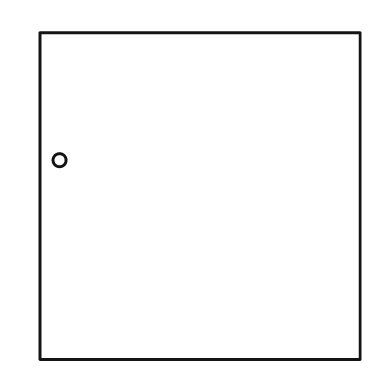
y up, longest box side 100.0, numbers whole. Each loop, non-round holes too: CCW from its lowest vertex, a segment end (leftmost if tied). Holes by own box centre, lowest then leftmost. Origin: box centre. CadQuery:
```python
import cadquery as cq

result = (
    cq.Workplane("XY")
    .moveTo(-49.0, -50.0)
    .lineTo(49.0, -50.0)
    .lineTo(49.0, 50.0)
    .lineTo(-49.0, 50.0)
    .close()
    .moveTo(-43.0, 11.0)
    .circle(2.0)
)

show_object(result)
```